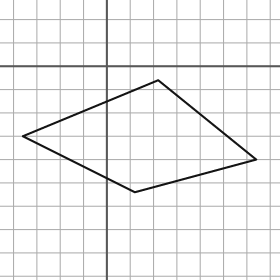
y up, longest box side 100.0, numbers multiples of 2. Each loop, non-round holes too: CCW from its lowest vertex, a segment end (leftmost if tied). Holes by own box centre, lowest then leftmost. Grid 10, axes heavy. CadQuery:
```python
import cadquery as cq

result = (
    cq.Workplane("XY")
    .moveTo(12.0, -54.0)
    .lineTo(64.0, -40.0)
    .lineTo(22.0, -6.0)
    .lineTo(-36.0, -30.0)
    .close()
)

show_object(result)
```